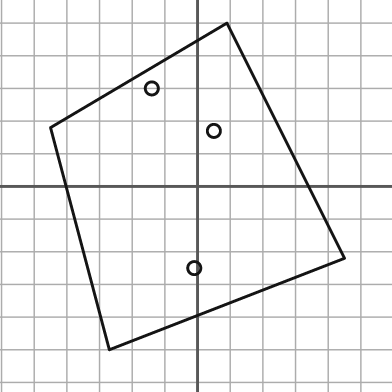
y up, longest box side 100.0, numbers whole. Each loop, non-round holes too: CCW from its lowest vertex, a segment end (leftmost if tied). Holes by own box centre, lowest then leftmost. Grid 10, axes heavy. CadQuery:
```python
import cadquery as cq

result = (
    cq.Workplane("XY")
    .moveTo(-27.0, -50.0)
    .lineTo(45.0, -22.0)
    .lineTo(9.0, 50.0)
    .lineTo(-45.0, 18.0)
    .close()
    .moveTo(-1.0, -25.0)
    .circle(2.0)
    .moveTo(5.0, 17.0)
    .circle(2.0)
    .moveTo(-14.0, 30.0)
    .circle(2.0)
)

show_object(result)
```